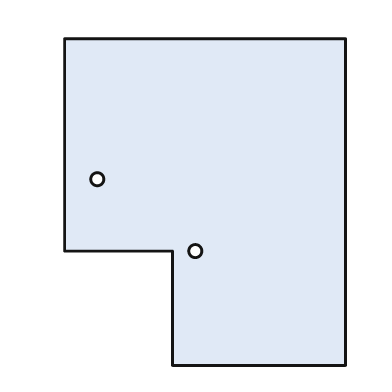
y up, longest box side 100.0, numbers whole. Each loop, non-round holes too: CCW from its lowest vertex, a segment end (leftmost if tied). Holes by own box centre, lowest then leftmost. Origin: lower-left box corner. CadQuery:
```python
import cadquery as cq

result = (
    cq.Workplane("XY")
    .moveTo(33.0, 0.0)
    .lineTo(86.0, 0.0)
    .lineTo(86.0, 100.0)
    .lineTo(0.0, 100.0)
    .lineTo(0.0, 35.0)
    .lineTo(33.0, 35.0)
    .close()
    .moveTo(40.0, 35.0)
    .circle(2.0)
    .moveTo(10.0, 57.0)
    .circle(2.0)
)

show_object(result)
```